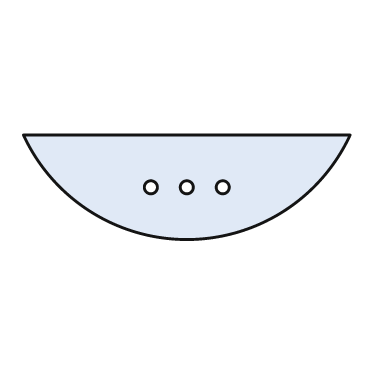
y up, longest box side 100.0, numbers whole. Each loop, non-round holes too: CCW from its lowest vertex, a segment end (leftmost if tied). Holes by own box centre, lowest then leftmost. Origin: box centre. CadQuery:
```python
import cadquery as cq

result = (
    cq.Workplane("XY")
    .moveTo(-50.0, 16.0)
    .threePointArc((0.0, -16.0), (50.0, 16.0))
    .close()
    .moveTo(-11.0, 0.0)
    .circle(2.0)
    .moveTo(0.0, 0.0)
    .circle(2.0)
    .moveTo(11.0, 0.0)
    .circle(2.0)
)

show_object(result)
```